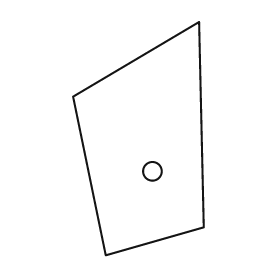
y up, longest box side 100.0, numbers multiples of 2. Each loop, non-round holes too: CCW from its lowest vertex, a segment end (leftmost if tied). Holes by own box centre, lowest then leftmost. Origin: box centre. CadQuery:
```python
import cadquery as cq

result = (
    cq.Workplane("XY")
    .moveTo(-14.0, -50.0)
    .lineTo(28.0, -38.0)
    .lineTo(26.0, 50.0)
    .lineTo(-28.0, 18.0)
    .close()
    .moveTo(6.0, -14.0)
    .circle(4.0)
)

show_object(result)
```